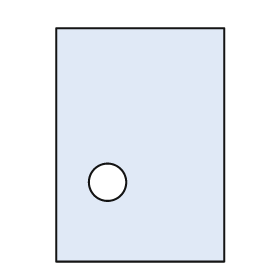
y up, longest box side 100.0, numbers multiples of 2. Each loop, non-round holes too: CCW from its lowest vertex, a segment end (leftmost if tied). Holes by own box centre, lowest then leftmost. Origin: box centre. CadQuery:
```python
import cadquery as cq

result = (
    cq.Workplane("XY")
    .moveTo(-36.0, -50.0)
    .lineTo(36.0, -50.0)
    .lineTo(36.0, 50.0)
    .lineTo(-36.0, 50.0)
    .close()
    .moveTo(-14.0, -16.0)
    .circle(8.0)
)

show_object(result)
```